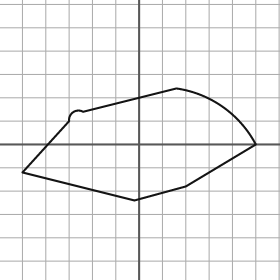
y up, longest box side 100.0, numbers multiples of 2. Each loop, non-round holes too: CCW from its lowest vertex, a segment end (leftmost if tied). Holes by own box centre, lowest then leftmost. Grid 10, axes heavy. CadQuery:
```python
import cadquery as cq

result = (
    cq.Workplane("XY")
    .moveTo(-2.0, -24.0)
    .lineTo(20.0, -18.0)
    .lineTo(50.0, 0.0)
    .threePointArc((36.0, 16.0), (16.0, 24.0))
    .lineTo(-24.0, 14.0)
    .threePointArc((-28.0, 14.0), (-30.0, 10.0))
    .lineTo(-50.0, -12.0)
    .close()
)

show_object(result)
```